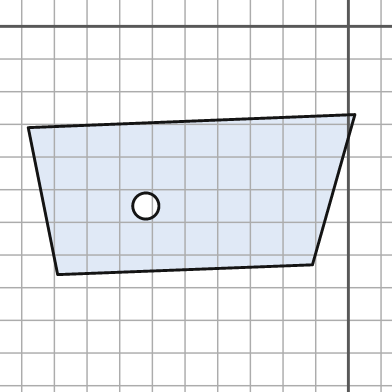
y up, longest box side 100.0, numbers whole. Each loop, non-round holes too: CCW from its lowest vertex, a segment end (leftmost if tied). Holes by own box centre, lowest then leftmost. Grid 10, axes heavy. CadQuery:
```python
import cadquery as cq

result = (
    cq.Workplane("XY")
    .moveTo(-89.0, -76.0)
    .lineTo(-11.0, -73.0)
    .lineTo(2.0, -27.0)
    .lineTo(-98.0, -31.0)
    .close()
    .moveTo(-62.0, -55.0)
    .circle(4.0)
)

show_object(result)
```